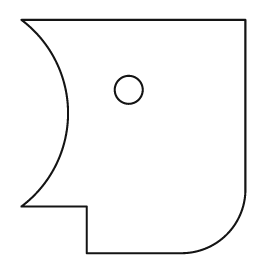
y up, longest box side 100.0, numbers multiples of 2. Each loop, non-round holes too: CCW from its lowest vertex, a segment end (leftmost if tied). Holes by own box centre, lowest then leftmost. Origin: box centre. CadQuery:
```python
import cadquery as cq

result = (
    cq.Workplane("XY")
    .moveTo(-20.0, -50.0)
    .lineTo(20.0, -50.0)
    .threePointArc((40.0, -42.0), (48.0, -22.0))
    .lineTo(48.0, 50.0)
    .lineTo(-48.0, 50.0)
    .threePointArc((-28.0, 10.0), (-48.0, -30.0))
    .lineTo(-20.0, -30.0)
    .close()
    .moveTo(-2.0, 20.0)
    .circle(6.0)
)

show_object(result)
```